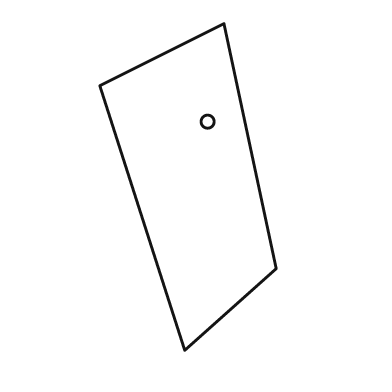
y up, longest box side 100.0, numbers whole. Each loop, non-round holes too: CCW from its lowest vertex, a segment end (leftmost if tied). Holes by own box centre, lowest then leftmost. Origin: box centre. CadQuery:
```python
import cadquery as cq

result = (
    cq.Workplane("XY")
    .moveTo(-1.0, -50.0)
    .lineTo(27.0, -25.0)
    .lineTo(11.0, 50.0)
    .lineTo(-27.0, 31.0)
    .close()
    .moveTo(6.0, 20.0)
    .circle(2.0)
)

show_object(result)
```